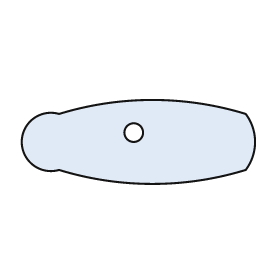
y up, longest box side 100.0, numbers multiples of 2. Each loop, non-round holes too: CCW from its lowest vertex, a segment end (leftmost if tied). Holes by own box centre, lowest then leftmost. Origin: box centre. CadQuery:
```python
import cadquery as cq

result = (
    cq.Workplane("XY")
    .moveTo(-34.0, -12.0)
    .threePointArc((6.0, -18.0), (46.0, -12.0))
    .threePointArc((50.0, 0.0), (46.0, 12.0))
    .threePointArc((6.0, 18.0), (-34.0, 12.0))
    .threePointArc((-50.0, 0.0), (-34.0, -12.0))
    .close()
    .moveTo(-2.0, 4.0)
    .circle(4.0)
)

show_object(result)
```